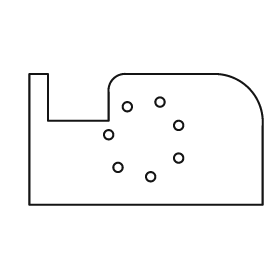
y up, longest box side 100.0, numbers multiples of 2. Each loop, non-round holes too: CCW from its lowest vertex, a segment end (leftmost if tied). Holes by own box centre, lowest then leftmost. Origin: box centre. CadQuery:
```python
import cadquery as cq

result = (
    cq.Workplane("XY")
    .moveTo(-50.0, -28.0)
    .lineTo(50.0, -28.0)
    .lineTo(50.0, 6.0)
    .threePointArc((44.0, 22.0), (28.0, 28.0))
    .lineTo(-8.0, 28.0)
    .threePointArc((-14.0, 26.0), (-16.0, 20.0))
    .lineTo(-16.0, 8.0)
    .lineTo(-42.0, 8.0)
    .lineTo(-42.0, 28.0)
    .lineTo(-50.0, 28.0)
    .close()
    .moveTo(2.0, -16.0)
    .circle(2.0)
    .moveTo(-12.0, -12.0)
    .circle(2.0)
    .moveTo(14.0, -8.0)
    .circle(2.0)
    .moveTo(-16.0, 2.0)
    .circle(2.0)
    .moveTo(14.0, 6.0)
    .circle(2.0)
    .moveTo(-8.0, 14.0)
    .circle(2.0)
    .moveTo(6.0, 16.0)
    .circle(2.0)
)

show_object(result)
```